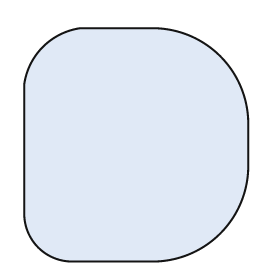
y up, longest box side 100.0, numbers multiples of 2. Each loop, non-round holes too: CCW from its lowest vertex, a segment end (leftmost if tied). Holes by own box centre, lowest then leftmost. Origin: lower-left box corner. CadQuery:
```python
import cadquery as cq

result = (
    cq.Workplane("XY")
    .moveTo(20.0, 0.0)
    .lineTo(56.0, 0.0)
    .threePointArc((84.0, 12.0), (96.0, 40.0))
    .lineTo(96.0, 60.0)
    .threePointArc((84.0, 88.0), (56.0, 100.0))
    .lineTo(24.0, 100.0)
    .threePointArc((8.0, 92.0), (0.0, 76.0))
    .lineTo(0.0, 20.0)
    .threePointArc((6.0, 6.0), (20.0, 0.0))
    .close()
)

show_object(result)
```